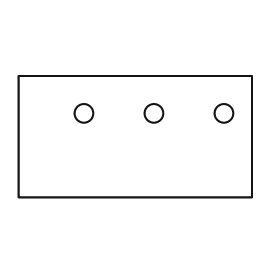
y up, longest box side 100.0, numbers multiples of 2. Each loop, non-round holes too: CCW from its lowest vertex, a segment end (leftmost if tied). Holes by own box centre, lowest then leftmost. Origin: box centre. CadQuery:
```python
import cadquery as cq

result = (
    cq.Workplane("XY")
    .moveTo(-50.0, -26.0)
    .lineTo(50.0, -26.0)
    .lineTo(50.0, 26.0)
    .lineTo(-50.0, 26.0)
    .close()
    .moveTo(-22.0, 10.0)
    .circle(4.0)
    .moveTo(8.0, 10.0)
    .circle(4.0)
    .moveTo(38.0, 10.0)
    .circle(4.0)
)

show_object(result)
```